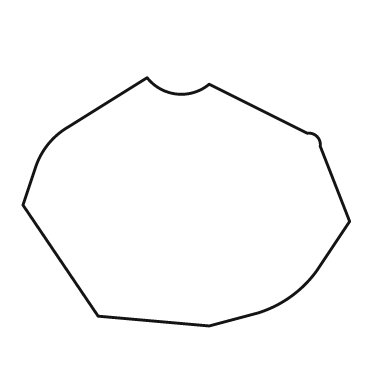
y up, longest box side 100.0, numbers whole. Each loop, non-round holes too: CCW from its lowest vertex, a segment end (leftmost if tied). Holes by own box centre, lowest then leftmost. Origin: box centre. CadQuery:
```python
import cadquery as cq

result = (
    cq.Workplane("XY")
    .moveTo(7.0, -38.0)
    .lineTo(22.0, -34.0)
    .threePointArc((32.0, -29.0), (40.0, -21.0))
    .lineTo(50.0, -6.0)
    .lineTo(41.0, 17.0)
    .threePointArc((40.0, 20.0), (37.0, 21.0))
    .lineTo(7.0, 36.0)
    .threePointArc((-3.0, 33.0), (-12.0, 38.0))
    .lineTo(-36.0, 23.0)
    .threePointArc((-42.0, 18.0), (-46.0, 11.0))
    .lineTo(-50.0, -1.0)
    .lineTo(-27.0, -35.0)
    .close()
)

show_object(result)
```